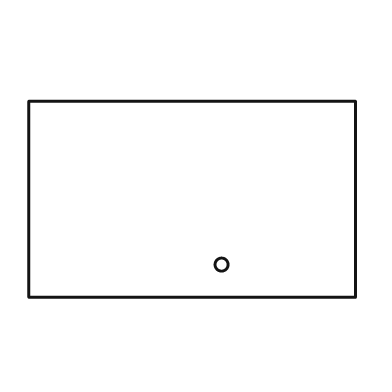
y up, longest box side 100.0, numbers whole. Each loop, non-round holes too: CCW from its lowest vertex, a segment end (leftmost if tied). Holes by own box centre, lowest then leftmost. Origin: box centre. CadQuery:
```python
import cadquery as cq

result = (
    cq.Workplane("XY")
    .moveTo(-50.0, -30.0)
    .lineTo(50.0, -30.0)
    .lineTo(50.0, 30.0)
    .lineTo(-50.0, 30.0)
    .close()
    .moveTo(9.0, -20.0)
    .circle(2.0)
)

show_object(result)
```